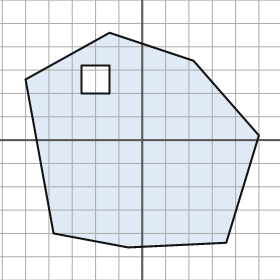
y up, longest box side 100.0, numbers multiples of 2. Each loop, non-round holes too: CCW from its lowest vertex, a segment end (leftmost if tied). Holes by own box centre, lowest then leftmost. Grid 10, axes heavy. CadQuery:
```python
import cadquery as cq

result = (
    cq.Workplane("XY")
    .moveTo(-6.0, -46.0)
    .lineTo(36.0, -44.0)
    .lineTo(50.0, 2.0)
    .lineTo(22.0, 34.0)
    .lineTo(-14.0, 46.0)
    .lineTo(-50.0, 26.0)
    .lineTo(-38.0, -40.0)
    .close()
    .moveTo(-26.0, 20.0)
    .lineTo(-14.0, 20.0)
    .lineTo(-14.0, 32.0)
    .lineTo(-26.0, 32.0)
    .close()
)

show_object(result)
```